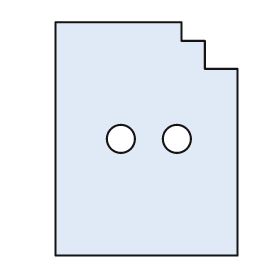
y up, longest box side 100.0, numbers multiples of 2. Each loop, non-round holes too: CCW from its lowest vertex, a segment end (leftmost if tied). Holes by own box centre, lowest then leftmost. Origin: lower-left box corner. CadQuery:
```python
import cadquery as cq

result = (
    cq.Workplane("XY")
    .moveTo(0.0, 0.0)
    .lineTo(78.0, 0.0)
    .lineTo(78.0, 80.0)
    .lineTo(64.0, 80.0)
    .lineTo(64.0, 92.0)
    .lineTo(54.0, 92.0)
    .lineTo(54.0, 100.0)
    .lineTo(0.0, 100.0)
    .close()
    .moveTo(28.0, 50.0)
    .circle(6.0)
    .moveTo(52.0, 50.0)
    .circle(6.0)
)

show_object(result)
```